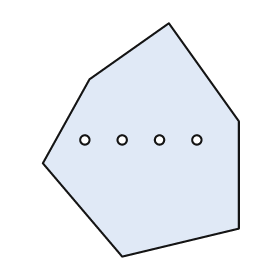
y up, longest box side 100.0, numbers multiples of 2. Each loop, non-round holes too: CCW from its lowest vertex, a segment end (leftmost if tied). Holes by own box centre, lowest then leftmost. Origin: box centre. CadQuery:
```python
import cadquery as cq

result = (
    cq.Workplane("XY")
    .moveTo(-8.0, -50.0)
    .lineTo(42.0, -38.0)
    .lineTo(42.0, 8.0)
    .lineTo(12.0, 50.0)
    .lineTo(-22.0, 26.0)
    .lineTo(-42.0, -10.0)
    .close()
    .moveTo(-24.0, 0.0)
    .circle(2.0)
    .moveTo(-8.0, 0.0)
    .circle(2.0)
    .moveTo(8.0, 0.0)
    .circle(2.0)
    .moveTo(24.0, 0.0)
    .circle(2.0)
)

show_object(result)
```